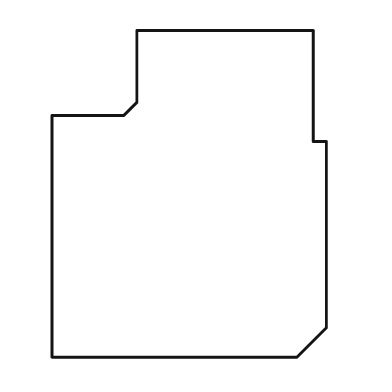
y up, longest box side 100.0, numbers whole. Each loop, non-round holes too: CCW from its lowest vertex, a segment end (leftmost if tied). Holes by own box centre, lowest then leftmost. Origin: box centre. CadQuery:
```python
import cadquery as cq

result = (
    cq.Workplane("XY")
    .moveTo(-42.0, -50.0)
    .lineTo(33.0, -50.0)
    .lineTo(42.0, -41.0)
    .lineTo(42.0, 16.0)
    .lineTo(38.0, 16.0)
    .lineTo(38.0, 50.0)
    .lineTo(-16.0, 50.0)
    .lineTo(-16.0, 28.0)
    .lineTo(-20.0, 24.0)
    .lineTo(-42.0, 24.0)
    .close()
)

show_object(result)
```